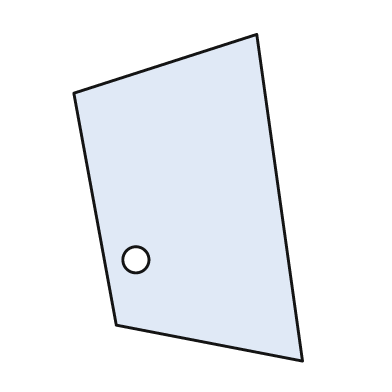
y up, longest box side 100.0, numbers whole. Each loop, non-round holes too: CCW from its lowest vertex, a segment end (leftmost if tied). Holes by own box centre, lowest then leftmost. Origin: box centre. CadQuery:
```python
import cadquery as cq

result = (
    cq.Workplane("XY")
    .moveTo(35.0, -50.0)
    .lineTo(21.0, 50.0)
    .lineTo(-35.0, 32.0)
    .lineTo(-22.0, -39.0)
    .close()
    .moveTo(-16.0, -19.0)
    .circle(4.0)
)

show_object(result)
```